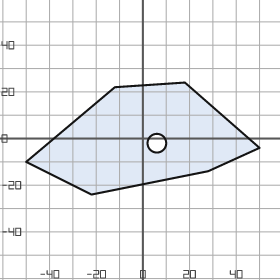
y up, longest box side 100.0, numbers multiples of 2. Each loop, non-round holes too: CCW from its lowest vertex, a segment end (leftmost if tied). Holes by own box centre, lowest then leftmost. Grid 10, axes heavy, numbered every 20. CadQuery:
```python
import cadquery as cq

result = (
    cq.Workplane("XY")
    .moveTo(-22.0, -24.0)
    .lineTo(28.0, -14.0)
    .lineTo(50.0, -4.0)
    .lineTo(18.0, 24.0)
    .lineTo(-12.0, 22.0)
    .lineTo(-50.0, -10.0)
    .close()
    .moveTo(6.0, -2.0)
    .circle(4.0)
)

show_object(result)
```